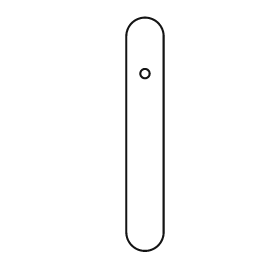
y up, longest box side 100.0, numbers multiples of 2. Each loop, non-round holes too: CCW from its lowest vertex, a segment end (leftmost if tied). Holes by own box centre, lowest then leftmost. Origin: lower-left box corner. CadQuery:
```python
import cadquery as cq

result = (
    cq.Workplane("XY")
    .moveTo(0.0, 8.0)
    .threePointArc((8.0, 0.0), (16.0, 8.0))
    .lineTo(16.0, 92.0)
    .threePointArc((8.0, 100.0), (0.0, 92.0))
    .close()
    .moveTo(8.0, 76.0)
    .circle(2.0)
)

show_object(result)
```